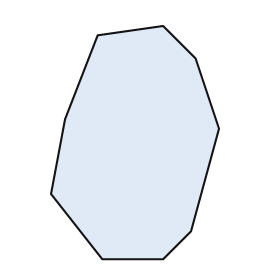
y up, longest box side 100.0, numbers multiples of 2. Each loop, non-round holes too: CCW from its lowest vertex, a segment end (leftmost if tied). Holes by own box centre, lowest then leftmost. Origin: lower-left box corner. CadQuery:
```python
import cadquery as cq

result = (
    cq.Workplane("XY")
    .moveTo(22.0, 0.0)
    .lineTo(48.0, 0.0)
    .lineTo(60.0, 12.0)
    .lineTo(72.0, 56.0)
    .lineTo(62.0, 86.0)
    .lineTo(48.0, 100.0)
    .lineTo(20.0, 96.0)
    .lineTo(6.0, 60.0)
    .lineTo(0.0, 28.0)
    .close()
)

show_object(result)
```